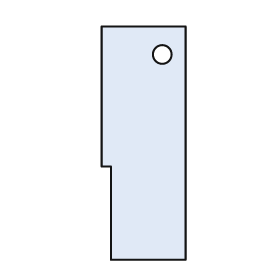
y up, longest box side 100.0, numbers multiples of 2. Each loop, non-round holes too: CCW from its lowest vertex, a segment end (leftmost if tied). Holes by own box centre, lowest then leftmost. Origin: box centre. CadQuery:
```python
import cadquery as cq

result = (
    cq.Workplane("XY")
    .moveTo(-14.0, -50.0)
    .lineTo(18.0, -50.0)
    .lineTo(18.0, 50.0)
    .lineTo(-18.0, 50.0)
    .lineTo(-18.0, -10.0)
    .lineTo(-14.0, -10.0)
    .close()
    .moveTo(8.0, 38.0)
    .circle(4.0)
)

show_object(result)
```